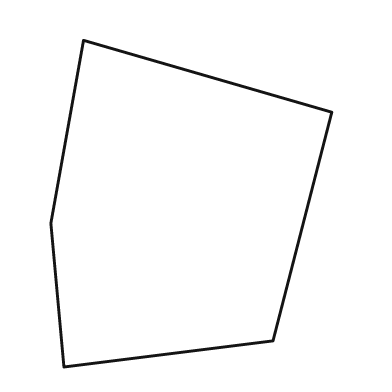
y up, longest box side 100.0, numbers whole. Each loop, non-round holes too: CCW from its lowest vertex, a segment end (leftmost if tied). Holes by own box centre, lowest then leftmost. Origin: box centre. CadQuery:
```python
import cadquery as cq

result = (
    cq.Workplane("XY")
    .moveTo(-39.0, -50.0)
    .lineTo(25.0, -42.0)
    .lineTo(43.0, 28.0)
    .lineTo(-33.0, 50.0)
    .lineTo(-43.0, -6.0)
    .close()
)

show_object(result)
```